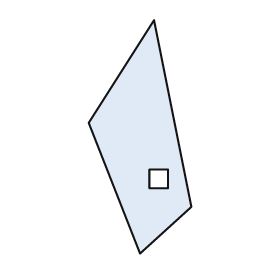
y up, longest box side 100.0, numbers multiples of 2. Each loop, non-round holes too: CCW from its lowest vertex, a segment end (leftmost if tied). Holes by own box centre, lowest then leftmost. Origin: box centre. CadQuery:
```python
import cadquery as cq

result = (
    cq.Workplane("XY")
    .moveTo(0.0, -50.0)
    .lineTo(22.0, -30.0)
    .lineTo(6.0, 50.0)
    .lineTo(-22.0, 6.0)
    .close()
    .moveTo(4.0, -22.0)
    .lineTo(12.0, -22.0)
    .lineTo(12.0, -14.0)
    .lineTo(4.0, -14.0)
    .close()
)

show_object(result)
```